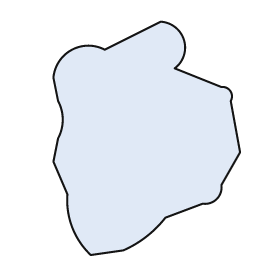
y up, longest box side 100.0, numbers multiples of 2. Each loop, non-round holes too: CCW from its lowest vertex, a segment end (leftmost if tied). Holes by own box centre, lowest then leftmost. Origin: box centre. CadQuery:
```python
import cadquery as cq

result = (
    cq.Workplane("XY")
    .moveTo(-24.0, -50.0)
    .lineTo(-10.0, -48.0)
    .threePointArc((0.0, -42.0), (8.0, -34.0))
    .lineTo(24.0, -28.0)
    .threePointArc((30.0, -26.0), (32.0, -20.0))
    .lineTo(40.0, -6.0)
    .lineTo(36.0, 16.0)
    .threePointArc((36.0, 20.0), (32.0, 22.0))
    .lineTo(12.0, 30.0)
    .threePointArc((16.0, 42.0), (6.0, 50.0))
    .lineTo(-18.0, 38.0)
    .threePointArc((-32.0, 38.0), (-40.0, 26.0))
    .lineTo(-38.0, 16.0)
    .threePointArc((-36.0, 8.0), (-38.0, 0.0))
    .lineTo(-40.0, -10.0)
    .lineTo(-34.0, -24.0)
    .threePointArc((-32.0, -38.0), (-24.0, -50.0))
    .close()
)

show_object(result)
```